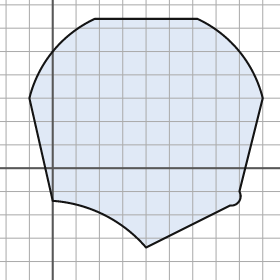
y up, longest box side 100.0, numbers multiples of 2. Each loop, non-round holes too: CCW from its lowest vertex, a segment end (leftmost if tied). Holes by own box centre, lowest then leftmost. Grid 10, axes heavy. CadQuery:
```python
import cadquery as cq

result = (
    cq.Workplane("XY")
    .moveTo(40.0, -34.0)
    .lineTo(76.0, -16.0)
    .threePointArc((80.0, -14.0), (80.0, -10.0))
    .lineTo(90.0, 30.0)
    .threePointArc((80.0, 50.0), (62.0, 64.0))
    .lineTo(18.0, 64.0)
    .threePointArc((0.0, 50.0), (-10.0, 30.0))
    .lineTo(0.0, -14.0)
    .threePointArc((22.0, -20.0), (40.0, -34.0))
    .close()
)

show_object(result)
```